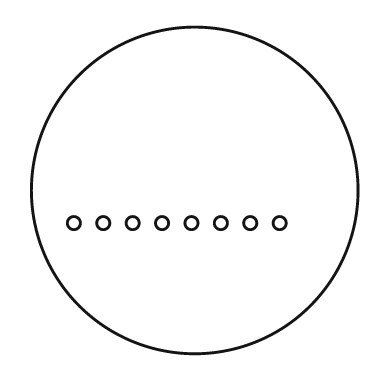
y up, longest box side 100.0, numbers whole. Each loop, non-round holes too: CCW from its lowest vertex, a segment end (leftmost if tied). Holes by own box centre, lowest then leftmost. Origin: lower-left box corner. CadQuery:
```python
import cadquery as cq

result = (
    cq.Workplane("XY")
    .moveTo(50.0, 50.0)
    .circle(50.0)
    .moveTo(13.0, 40.0)
    .circle(2.0)
    .moveTo(22.0, 40.0)
    .circle(2.0)
    .moveTo(31.0, 40.0)
    .circle(2.0)
    .moveTo(40.0, 40.0)
    .circle(2.0)
    .moveTo(49.0, 40.0)
    .circle(2.0)
    .moveTo(58.0, 40.0)
    .circle(2.0)
    .moveTo(67.0, 40.0)
    .circle(2.0)
    .moveTo(76.0, 40.0)
    .circle(2.0)
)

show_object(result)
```